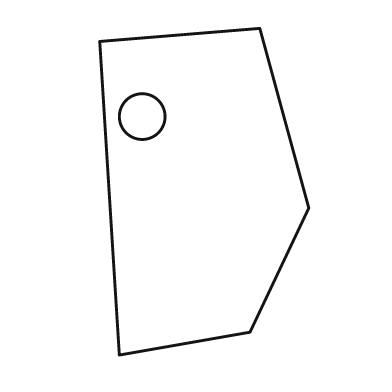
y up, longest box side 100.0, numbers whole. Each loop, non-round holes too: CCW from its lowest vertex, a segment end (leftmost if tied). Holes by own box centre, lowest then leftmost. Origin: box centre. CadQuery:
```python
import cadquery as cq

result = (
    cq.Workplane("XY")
    .moveTo(-26.0, -50.0)
    .lineTo(14.0, -43.0)
    .lineTo(32.0, -5.0)
    .lineTo(17.0, 50.0)
    .lineTo(-32.0, 46.0)
    .close()
    .moveTo(-19.0, 23.0)
    .circle(7.0)
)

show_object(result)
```